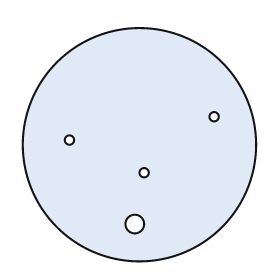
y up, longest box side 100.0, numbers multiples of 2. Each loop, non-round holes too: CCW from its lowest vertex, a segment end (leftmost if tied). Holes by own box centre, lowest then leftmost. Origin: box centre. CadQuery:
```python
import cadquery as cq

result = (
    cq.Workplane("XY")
    .moveTo(0.0, 0.0)
    .circle(50.0)
    .moveTo(-2.0, -34.0)
    .circle(4.0)
    .moveTo(2.0, -12.0)
    .circle(2.0)
    .moveTo(-30.0, 2.0)
    .circle(2.0)
    .moveTo(32.0, 12.0)
    .circle(2.0)
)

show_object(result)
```